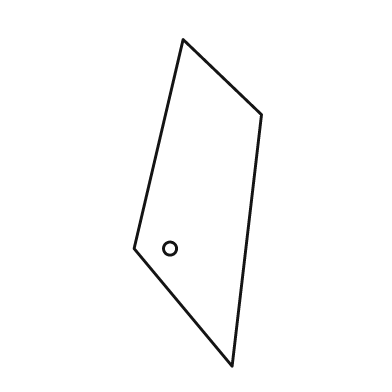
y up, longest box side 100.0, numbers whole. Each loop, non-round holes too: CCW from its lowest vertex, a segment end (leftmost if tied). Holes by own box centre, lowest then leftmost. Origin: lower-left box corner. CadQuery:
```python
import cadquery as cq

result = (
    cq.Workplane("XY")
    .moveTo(30.0, 0.0)
    .lineTo(39.0, 77.0)
    .lineTo(15.0, 100.0)
    .lineTo(0.0, 36.0)
    .close()
    .moveTo(11.0, 36.0)
    .circle(2.0)
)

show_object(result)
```